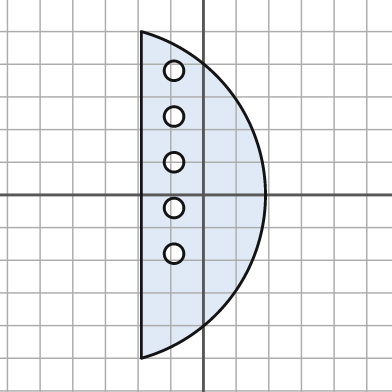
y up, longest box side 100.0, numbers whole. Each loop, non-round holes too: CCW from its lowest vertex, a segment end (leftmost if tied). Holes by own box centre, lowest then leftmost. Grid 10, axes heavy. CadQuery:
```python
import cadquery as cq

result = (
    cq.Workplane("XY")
    .moveTo(-19.0, -50.0)
    .threePointArc((19.0, 0.0), (-19.0, 50.0))
    .close()
    .moveTo(-9.0, -18.0)
    .circle(3.0)
    .moveTo(-9.0, -4.0)
    .circle(3.0)
    .moveTo(-9.0, 10.0)
    .circle(3.0)
    .moveTo(-9.0, 24.0)
    .circle(3.0)
    .moveTo(-9.0, 38.0)
    .circle(3.0)
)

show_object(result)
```